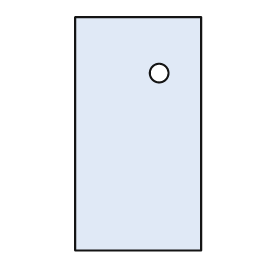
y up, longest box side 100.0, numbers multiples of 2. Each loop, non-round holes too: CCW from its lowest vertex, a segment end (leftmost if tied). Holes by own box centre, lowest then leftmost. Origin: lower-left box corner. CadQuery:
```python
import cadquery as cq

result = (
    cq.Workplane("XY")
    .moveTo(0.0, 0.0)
    .lineTo(54.0, 0.0)
    .lineTo(54.0, 100.0)
    .lineTo(0.0, 100.0)
    .close()
    .moveTo(36.0, 76.0)
    .circle(4.0)
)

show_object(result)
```